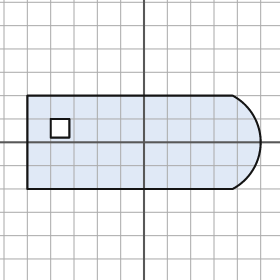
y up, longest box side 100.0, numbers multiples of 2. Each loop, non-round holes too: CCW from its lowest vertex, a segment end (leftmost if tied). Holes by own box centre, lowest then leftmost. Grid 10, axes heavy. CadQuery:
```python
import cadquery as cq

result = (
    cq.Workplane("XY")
    .moveTo(-50.0, -20.0)
    .lineTo(38.0, -20.0)
    .threePointArc((50.0, 0.0), (38.0, 20.0))
    .lineTo(-50.0, 20.0)
    .close()
    .moveTo(-40.0, 2.0)
    .lineTo(-32.0, 2.0)
    .lineTo(-32.0, 10.0)
    .lineTo(-40.0, 10.0)
    .close()
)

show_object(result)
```